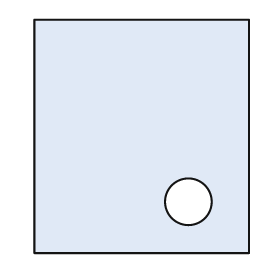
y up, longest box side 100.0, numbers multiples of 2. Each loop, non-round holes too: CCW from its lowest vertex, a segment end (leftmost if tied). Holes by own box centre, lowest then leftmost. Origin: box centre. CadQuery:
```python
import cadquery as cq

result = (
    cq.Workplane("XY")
    .moveTo(-46.0, -50.0)
    .lineTo(46.0, -50.0)
    .lineTo(46.0, 50.0)
    .lineTo(-46.0, 50.0)
    .close()
    .moveTo(20.0, -28.0)
    .circle(10.0)
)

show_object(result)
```